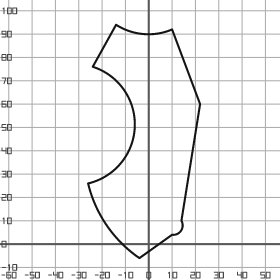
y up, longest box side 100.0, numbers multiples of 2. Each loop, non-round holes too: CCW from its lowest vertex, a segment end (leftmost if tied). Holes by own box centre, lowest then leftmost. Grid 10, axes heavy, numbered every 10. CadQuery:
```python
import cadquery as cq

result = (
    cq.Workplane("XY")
    .moveTo(-4.0, -6.0)
    .lineTo(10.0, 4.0)
    .threePointArc((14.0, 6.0), (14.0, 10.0))
    .lineTo(22.0, 60.0)
    .lineTo(10.0, 92.0)
    .threePointArc((-2.0, 90.0), (-14.0, 94.0))
    .lineTo(-24.0, 76.0)
    .threePointArc((-6.0, 50.0), (-26.0, 26.0))
    .threePointArc((-18.0, 8.0), (-4.0, -6.0))
    .close()
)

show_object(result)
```